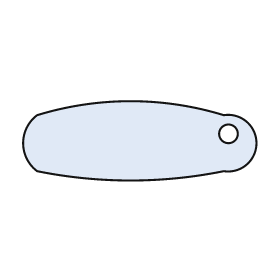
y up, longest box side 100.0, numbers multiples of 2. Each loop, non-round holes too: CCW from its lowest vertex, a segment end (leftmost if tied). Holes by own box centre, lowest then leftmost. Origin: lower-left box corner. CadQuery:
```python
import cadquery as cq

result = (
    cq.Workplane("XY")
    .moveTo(6.0, 4.0)
    .threePointArc((46.0, 0.0), (86.0, 4.0))
    .threePointArc((100.0, 16.0), (86.0, 28.0))
    .threePointArc((46.0, 34.0), (6.0, 28.0))
    .threePointArc((0.0, 16.0), (6.0, 4.0))
    .close()
    .moveTo(88.0, 20.0)
    .circle(4.0)
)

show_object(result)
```